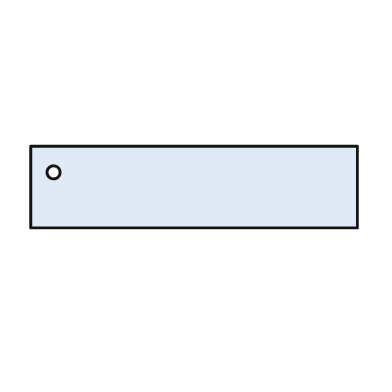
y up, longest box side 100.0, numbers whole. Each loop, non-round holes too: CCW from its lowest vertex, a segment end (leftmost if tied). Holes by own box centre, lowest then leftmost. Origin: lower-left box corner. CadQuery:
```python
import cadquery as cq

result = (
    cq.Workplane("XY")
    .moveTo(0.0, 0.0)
    .lineTo(100.0, 0.0)
    .lineTo(100.0, 25.0)
    .lineTo(0.0, 25.0)
    .close()
    .moveTo(7.0, 17.0)
    .circle(2.0)
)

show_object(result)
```